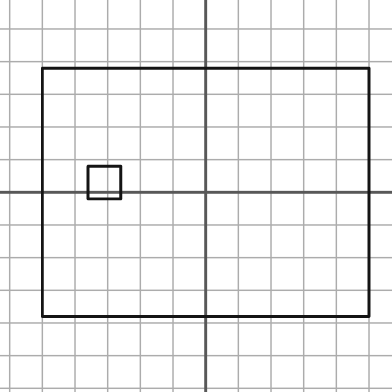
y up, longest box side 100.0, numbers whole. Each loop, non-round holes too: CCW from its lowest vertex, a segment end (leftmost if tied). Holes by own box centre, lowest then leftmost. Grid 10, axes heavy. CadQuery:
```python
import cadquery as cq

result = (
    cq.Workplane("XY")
    .moveTo(-50.0, -38.0)
    .lineTo(50.0, -38.0)
    .lineTo(50.0, 38.0)
    .lineTo(-50.0, 38.0)
    .close()
    .moveTo(-36.0, -2.0)
    .lineTo(-26.0, -2.0)
    .lineTo(-26.0, 8.0)
    .lineTo(-36.0, 8.0)
    .close()
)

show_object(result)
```